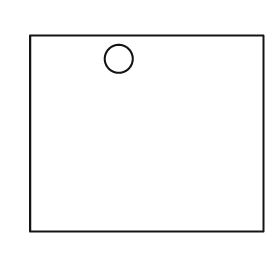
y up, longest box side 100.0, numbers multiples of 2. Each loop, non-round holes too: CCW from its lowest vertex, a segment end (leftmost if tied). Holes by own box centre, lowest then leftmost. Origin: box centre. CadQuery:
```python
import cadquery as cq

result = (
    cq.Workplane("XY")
    .moveTo(-50.0, -42.0)
    .lineTo(50.0, -42.0)
    .lineTo(50.0, 42.0)
    .lineTo(-50.0, 42.0)
    .close()
    .moveTo(-12.0, 32.0)
    .circle(6.0)
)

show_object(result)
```